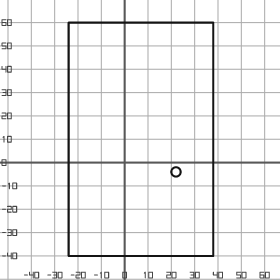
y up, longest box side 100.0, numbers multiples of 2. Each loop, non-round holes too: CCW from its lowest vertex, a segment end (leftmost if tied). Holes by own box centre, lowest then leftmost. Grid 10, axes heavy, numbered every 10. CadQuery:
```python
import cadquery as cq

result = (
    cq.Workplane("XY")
    .moveTo(-24.0, -40.0)
    .lineTo(38.0, -40.0)
    .lineTo(38.0, 60.0)
    .lineTo(-24.0, 60.0)
    .close()
    .moveTo(22.0, -4.0)
    .circle(2.0)
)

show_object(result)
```